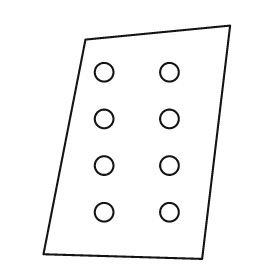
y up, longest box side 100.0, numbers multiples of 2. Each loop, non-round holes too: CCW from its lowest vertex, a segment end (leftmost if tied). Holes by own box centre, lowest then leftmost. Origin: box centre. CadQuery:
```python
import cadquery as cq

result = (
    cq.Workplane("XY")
    .moveTo(28.0, -50.0)
    .lineTo(40.0, 50.0)
    .lineTo(-22.0, 44.0)
    .lineTo(-40.0, -48.0)
    .close()
    .moveTo(-14.0, -30.0)
    .circle(4.0)
    .moveTo(14.0, -30.0)
    .circle(4.0)
    .moveTo(-14.0, -10.0)
    .circle(4.0)
    .moveTo(14.0, -10.0)
    .circle(4.0)
    .moveTo(-14.0, 10.0)
    .circle(4.0)
    .moveTo(14.0, 10.0)
    .circle(4.0)
    .moveTo(-14.0, 30.0)
    .circle(4.0)
    .moveTo(14.0, 30.0)
    .circle(4.0)
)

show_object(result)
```